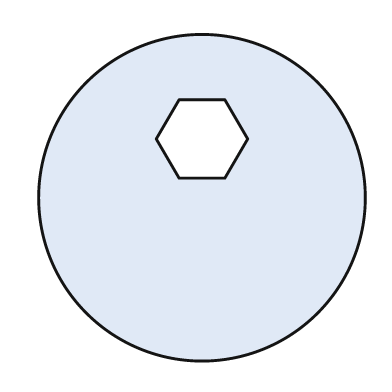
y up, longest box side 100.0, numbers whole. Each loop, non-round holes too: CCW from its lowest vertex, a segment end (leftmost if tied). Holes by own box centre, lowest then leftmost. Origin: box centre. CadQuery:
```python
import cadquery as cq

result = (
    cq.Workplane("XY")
    .moveTo(0.0, 0.0)
    .circle(50.0)
    .moveTo(-7.0, 6.0)
    .lineTo(7.0, 6.0)
    .lineTo(14.0, 18.0)
    .lineTo(7.0, 30.0)
    .lineTo(-7.0, 30.0)
    .lineTo(-14.0, 18.0)
    .close()
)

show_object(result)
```